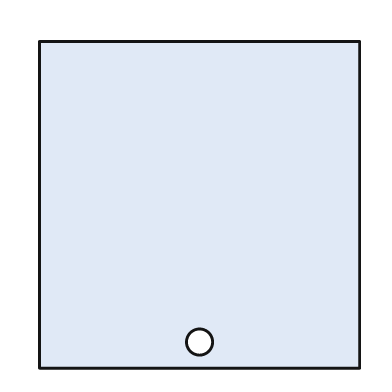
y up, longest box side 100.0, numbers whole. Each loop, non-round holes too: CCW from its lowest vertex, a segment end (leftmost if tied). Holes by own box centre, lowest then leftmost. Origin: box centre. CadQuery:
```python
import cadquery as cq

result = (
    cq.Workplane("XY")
    .moveTo(-49.0, -50.0)
    .lineTo(49.0, -50.0)
    .lineTo(49.0, 50.0)
    .lineTo(-49.0, 50.0)
    .close()
    .moveTo(0.0, -42.0)
    .circle(4.0)
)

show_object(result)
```